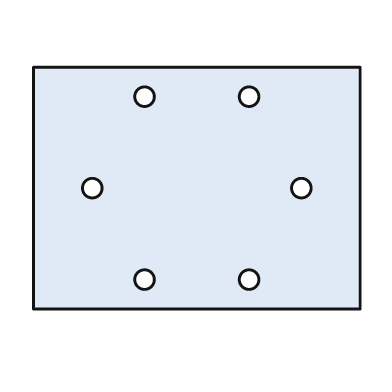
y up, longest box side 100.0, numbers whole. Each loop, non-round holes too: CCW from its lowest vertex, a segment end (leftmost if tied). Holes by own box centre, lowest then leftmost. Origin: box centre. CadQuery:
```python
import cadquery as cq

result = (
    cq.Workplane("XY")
    .moveTo(-50.0, -37.0)
    .lineTo(50.0, -37.0)
    .lineTo(50.0, 37.0)
    .lineTo(-50.0, 37.0)
    .close()
    .moveTo(-16.0, -28.0)
    .circle(3.0)
    .moveTo(16.0, -28.0)
    .circle(3.0)
    .moveTo(-32.0, 0.0)
    .circle(3.0)
    .moveTo(32.0, 0.0)
    .circle(3.0)
    .moveTo(-16.0, 28.0)
    .circle(3.0)
    .moveTo(16.0, 28.0)
    .circle(3.0)
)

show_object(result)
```